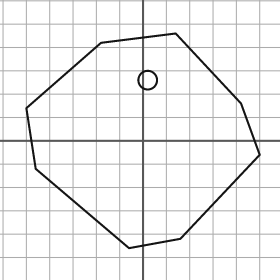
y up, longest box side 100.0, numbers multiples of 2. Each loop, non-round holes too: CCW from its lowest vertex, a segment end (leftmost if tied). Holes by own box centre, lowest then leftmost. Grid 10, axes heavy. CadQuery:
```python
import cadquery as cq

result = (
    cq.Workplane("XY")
    .moveTo(-6.0, -46.0)
    .lineTo(16.0, -42.0)
    .lineTo(50.0, -6.0)
    .lineTo(42.0, 16.0)
    .lineTo(14.0, 46.0)
    .lineTo(-18.0, 42.0)
    .lineTo(-50.0, 14.0)
    .lineTo(-46.0, -12.0)
    .close()
    .moveTo(2.0, 26.0)
    .circle(4.0)
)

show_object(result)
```